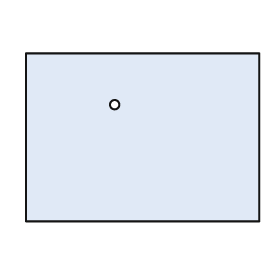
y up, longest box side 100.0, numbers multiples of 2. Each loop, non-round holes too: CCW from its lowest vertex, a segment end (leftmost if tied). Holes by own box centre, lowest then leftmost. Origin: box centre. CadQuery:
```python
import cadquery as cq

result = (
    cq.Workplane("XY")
    .moveTo(-50.0, -36.0)
    .lineTo(50.0, -36.0)
    .lineTo(50.0, 36.0)
    .lineTo(-50.0, 36.0)
    .close()
    .moveTo(-12.0, 14.0)
    .circle(2.0)
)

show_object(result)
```